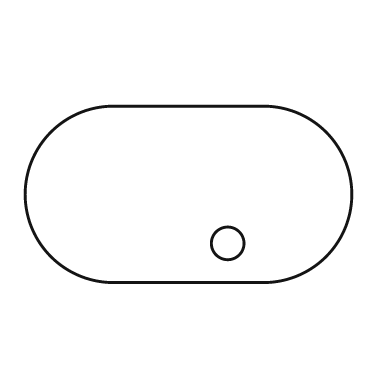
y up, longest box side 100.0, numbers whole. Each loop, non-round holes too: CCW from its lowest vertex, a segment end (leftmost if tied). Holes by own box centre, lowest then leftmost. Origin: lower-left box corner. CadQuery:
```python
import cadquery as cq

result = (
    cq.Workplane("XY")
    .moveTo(27.0, 0.0)
    .lineTo(73.0, 0.0)
    .threePointArc((100.0, 27.0), (73.0, 54.0))
    .lineTo(27.0, 54.0)
    .threePointArc((0.0, 27.0), (27.0, 0.0))
    .close()
    .moveTo(62.0, 12.0)
    .circle(5.0)
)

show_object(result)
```